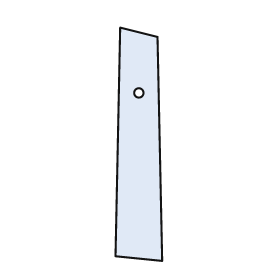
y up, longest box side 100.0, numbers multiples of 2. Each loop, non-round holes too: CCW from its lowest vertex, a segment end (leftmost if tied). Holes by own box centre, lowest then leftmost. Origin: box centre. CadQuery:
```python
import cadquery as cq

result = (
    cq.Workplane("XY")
    .moveTo(10.0, -50.0)
    .lineTo(8.0, 46.0)
    .lineTo(-8.0, 50.0)
    .lineTo(-10.0, -48.0)
    .close()
    .moveTo(0.0, 22.0)
    .circle(2.0)
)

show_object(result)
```